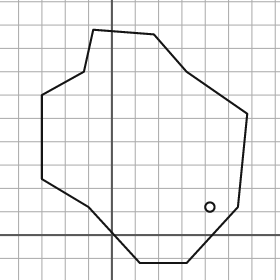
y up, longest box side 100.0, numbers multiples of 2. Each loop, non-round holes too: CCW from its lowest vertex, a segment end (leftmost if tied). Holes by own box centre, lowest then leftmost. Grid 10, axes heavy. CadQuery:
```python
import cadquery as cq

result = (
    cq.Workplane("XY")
    .moveTo(12.0, -12.0)
    .lineTo(32.0, -12.0)
    .lineTo(54.0, 12.0)
    .lineTo(58.0, 52.0)
    .lineTo(32.0, 70.0)
    .lineTo(18.0, 86.0)
    .lineTo(-8.0, 88.0)
    .lineTo(-12.0, 70.0)
    .lineTo(-30.0, 60.0)
    .lineTo(-30.0, 24.0)
    .lineTo(-10.0, 12.0)
    .close()
    .moveTo(42.0, 12.0)
    .circle(2.0)
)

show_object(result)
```